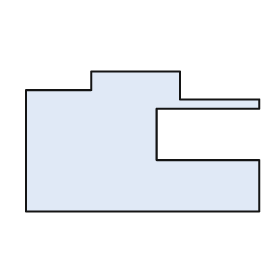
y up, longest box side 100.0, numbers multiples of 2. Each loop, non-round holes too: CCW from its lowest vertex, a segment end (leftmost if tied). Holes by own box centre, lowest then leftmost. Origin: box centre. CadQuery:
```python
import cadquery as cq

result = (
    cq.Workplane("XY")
    .moveTo(-50.0, -30.0)
    .lineTo(50.0, -30.0)
    .lineTo(50.0, -8.0)
    .lineTo(6.0, -8.0)
    .lineTo(6.0, 14.0)
    .lineTo(50.0, 14.0)
    .lineTo(50.0, 18.0)
    .lineTo(16.0, 18.0)
    .lineTo(16.0, 30.0)
    .lineTo(-22.0, 30.0)
    .lineTo(-22.0, 22.0)
    .lineTo(-50.0, 22.0)
    .close()
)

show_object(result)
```